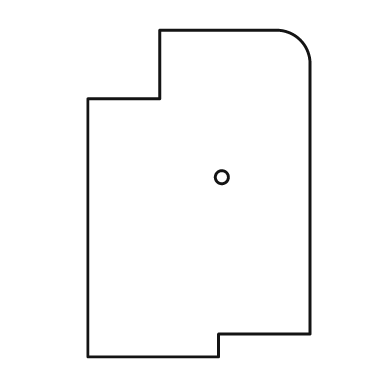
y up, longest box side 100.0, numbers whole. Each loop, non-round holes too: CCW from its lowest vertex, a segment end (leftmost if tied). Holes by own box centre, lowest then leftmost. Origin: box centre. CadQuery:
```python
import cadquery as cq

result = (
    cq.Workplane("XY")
    .moveTo(-34.0, -50.0)
    .lineTo(6.0, -50.0)
    .lineTo(6.0, -43.0)
    .lineTo(34.0, -43.0)
    .lineTo(34.0, 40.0)
    .threePointArc((31.0, 47.0), (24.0, 50.0))
    .lineTo(-12.0, 50.0)
    .lineTo(-12.0, 29.0)
    .lineTo(-34.0, 29.0)
    .close()
    .moveTo(7.0, 5.0)
    .circle(2.0)
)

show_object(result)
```